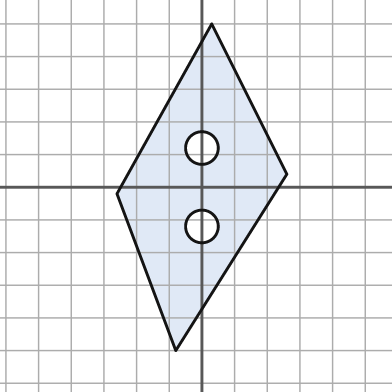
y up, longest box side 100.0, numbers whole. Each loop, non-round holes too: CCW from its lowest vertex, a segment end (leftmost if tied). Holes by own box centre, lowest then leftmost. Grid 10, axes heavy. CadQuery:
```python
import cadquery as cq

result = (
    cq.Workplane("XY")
    .moveTo(-8.0, -50.0)
    .lineTo(26.0, 4.0)
    .lineTo(3.0, 50.0)
    .lineTo(-26.0, -2.0)
    .close()
    .moveTo(0.0, -12.0)
    .circle(5.0)
    .moveTo(0.0, 12.0)
    .circle(5.0)
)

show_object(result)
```